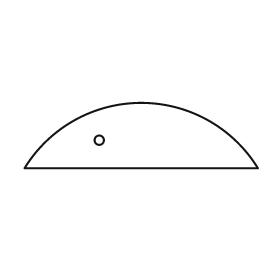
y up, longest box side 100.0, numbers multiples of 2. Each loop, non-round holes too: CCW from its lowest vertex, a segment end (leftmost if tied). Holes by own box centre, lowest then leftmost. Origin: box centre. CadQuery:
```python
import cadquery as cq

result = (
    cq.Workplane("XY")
    .moveTo(-50.0, -14.0)
    .lineTo(50.0, -14.0)
    .threePointArc((0.0, 14.0), (-50.0, -14.0))
    .close()
    .moveTo(-18.0, -2.0)
    .circle(2.0)
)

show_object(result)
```